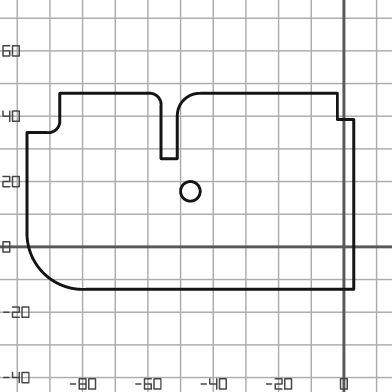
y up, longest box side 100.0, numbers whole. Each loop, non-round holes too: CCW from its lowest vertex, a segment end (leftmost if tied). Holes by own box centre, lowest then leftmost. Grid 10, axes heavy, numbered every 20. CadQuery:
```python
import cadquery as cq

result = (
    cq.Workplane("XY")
    .moveTo(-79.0, -13.0)
    .lineTo(3.0, -13.0)
    .lineTo(3.0, 39.0)
    .lineTo(-2.0, 39.0)
    .lineTo(-2.0, 47.0)
    .lineTo(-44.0, 47.0)
    .threePointArc((-49.0, 45.0), (-51.0, 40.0))
    .lineTo(-51.0, 27.0)
    .lineTo(-56.0, 27.0)
    .lineTo(-56.0, 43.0)
    .threePointArc((-57.0, 46.0), (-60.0, 47.0))
    .lineTo(-87.0, 47.0)
    .lineTo(-87.0, 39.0)
    .threePointArc((-88.0, 36.0), (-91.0, 35.0))
    .lineTo(-97.0, 35.0)
    .lineTo(-97.0, 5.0)
    .threePointArc((-92.0, -8.0), (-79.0, -13.0))
    .close()
    .moveTo(-47.0, 17.0)
    .circle(3.0)
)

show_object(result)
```